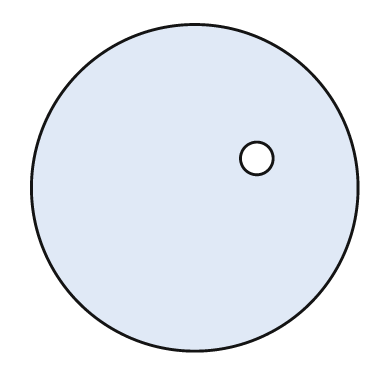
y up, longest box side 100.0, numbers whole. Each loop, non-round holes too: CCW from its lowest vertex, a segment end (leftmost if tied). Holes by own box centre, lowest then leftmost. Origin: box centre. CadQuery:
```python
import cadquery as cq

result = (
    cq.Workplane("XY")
    .moveTo(0.0, 0.0)
    .circle(50.0)
    .moveTo(19.0, 9.0)
    .circle(5.0)
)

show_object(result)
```